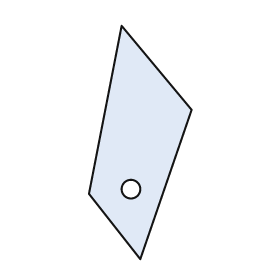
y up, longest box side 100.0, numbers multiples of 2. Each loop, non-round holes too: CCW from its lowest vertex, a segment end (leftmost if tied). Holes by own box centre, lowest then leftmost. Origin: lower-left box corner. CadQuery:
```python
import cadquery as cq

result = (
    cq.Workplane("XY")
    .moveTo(22.0, 0.0)
    .lineTo(44.0, 64.0)
    .lineTo(14.0, 100.0)
    .lineTo(0.0, 28.0)
    .close()
    .moveTo(18.0, 30.0)
    .circle(4.0)
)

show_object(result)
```